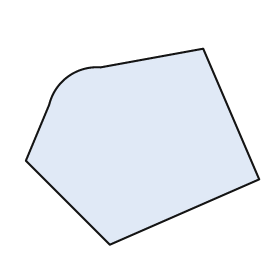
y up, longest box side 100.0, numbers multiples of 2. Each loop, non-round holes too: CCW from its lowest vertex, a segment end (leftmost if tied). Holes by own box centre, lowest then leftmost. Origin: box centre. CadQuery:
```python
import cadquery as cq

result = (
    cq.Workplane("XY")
    .moveTo(-14.0, -42.0)
    .lineTo(50.0, -14.0)
    .lineTo(26.0, 42.0)
    .lineTo(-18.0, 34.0)
    .threePointArc((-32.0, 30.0), (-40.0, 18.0))
    .lineTo(-50.0, -6.0)
    .close()
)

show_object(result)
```